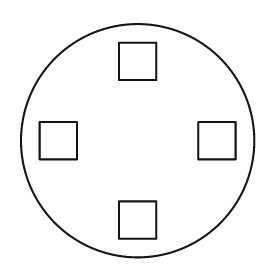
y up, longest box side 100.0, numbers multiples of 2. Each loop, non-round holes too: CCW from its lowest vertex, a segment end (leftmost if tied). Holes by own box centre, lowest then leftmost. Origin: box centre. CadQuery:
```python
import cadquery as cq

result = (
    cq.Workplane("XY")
    .moveTo(0.0, 0.0)
    .circle(50.0)
    .moveTo(-8.0, -42.0)
    .lineTo(8.0, -42.0)
    .lineTo(8.0, -26.0)
    .lineTo(-8.0, -26.0)
    .close()
    .moveTo(-42.0, -8.0)
    .lineTo(-26.0, -8.0)
    .lineTo(-26.0, 8.0)
    .lineTo(-42.0, 8.0)
    .close()
    .moveTo(26.0, -8.0)
    .lineTo(42.0, -8.0)
    .lineTo(42.0, 8.0)
    .lineTo(26.0, 8.0)
    .close()
    .moveTo(-8.0, 26.0)
    .lineTo(8.0, 26.0)
    .lineTo(8.0, 42.0)
    .lineTo(-8.0, 42.0)
    .close()
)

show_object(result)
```